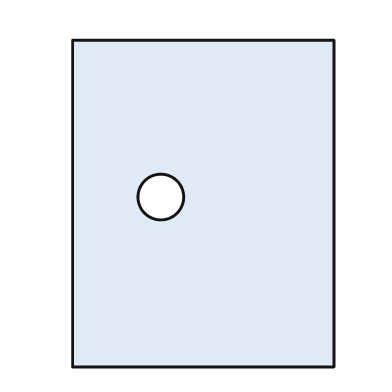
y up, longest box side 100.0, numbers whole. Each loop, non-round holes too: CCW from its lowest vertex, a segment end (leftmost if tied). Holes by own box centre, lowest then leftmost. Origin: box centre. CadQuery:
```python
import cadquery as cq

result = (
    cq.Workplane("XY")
    .moveTo(-40.0, -50.0)
    .lineTo(40.0, -50.0)
    .lineTo(40.0, 50.0)
    .lineTo(-40.0, 50.0)
    .close()
    .moveTo(-13.0, 2.0)
    .circle(7.0)
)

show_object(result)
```